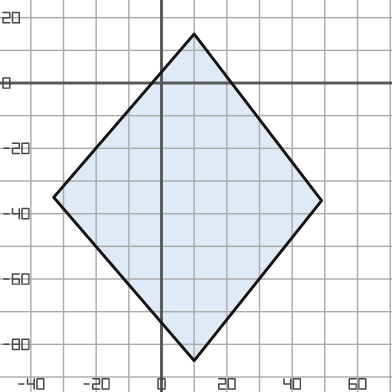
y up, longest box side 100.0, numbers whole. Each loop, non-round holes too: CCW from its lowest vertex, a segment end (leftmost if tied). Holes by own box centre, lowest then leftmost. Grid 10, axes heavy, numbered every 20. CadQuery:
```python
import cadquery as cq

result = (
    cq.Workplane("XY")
    .moveTo(10.0, -85.0)
    .lineTo(49.0, -36.0)
    .lineTo(10.0, 15.0)
    .lineTo(-33.0, -35.0)
    .close()
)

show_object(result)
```